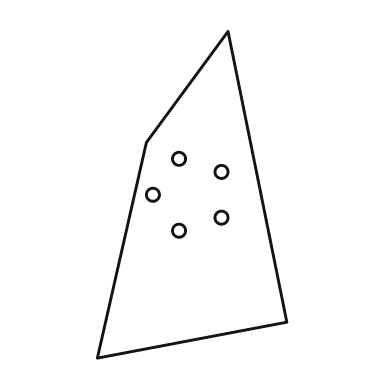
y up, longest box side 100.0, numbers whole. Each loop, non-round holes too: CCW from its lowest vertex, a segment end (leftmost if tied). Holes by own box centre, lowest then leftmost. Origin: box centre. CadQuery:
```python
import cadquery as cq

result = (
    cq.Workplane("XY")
    .moveTo(-29.0, -50.0)
    .lineTo(29.0, -39.0)
    .lineTo(11.0, 50.0)
    .lineTo(-14.0, 16.0)
    .close()
    .moveTo(-4.0, -11.0)
    .circle(2.0)
    .moveTo(9.0, -7.0)
    .circle(2.0)
    .moveTo(-12.0, 0.0)
    .circle(2.0)
    .moveTo(9.0, 7.0)
    .circle(2.0)
    .moveTo(-4.0, 11.0)
    .circle(2.0)
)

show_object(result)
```